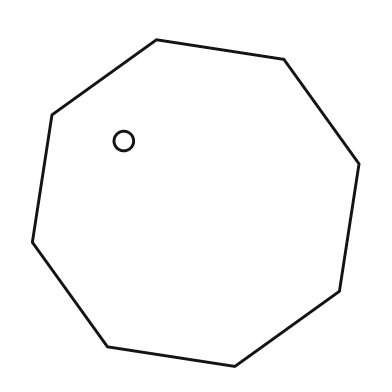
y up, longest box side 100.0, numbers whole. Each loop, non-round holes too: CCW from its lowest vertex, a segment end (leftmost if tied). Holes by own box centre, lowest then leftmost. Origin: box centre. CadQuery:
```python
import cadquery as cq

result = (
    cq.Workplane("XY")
    .moveTo(12.0, -50.0)
    .lineTo(44.0, -27.0)
    .lineTo(50.0, 12.0)
    .lineTo(27.0, 44.0)
    .lineTo(-12.0, 50.0)
    .lineTo(-44.0, 27.0)
    .lineTo(-50.0, -12.0)
    .lineTo(-27.0, -44.0)
    .close()
    .moveTo(-22.0, 19.0)
    .circle(3.0)
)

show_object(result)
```